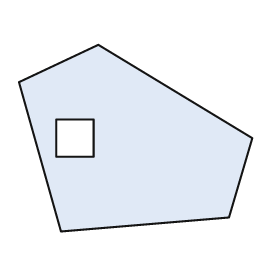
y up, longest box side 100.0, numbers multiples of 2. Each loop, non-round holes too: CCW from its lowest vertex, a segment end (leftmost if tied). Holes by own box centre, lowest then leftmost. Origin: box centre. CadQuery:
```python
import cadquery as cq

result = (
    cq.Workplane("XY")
    .moveTo(-32.0, -40.0)
    .lineTo(40.0, -34.0)
    .lineTo(50.0, 0.0)
    .lineTo(-16.0, 40.0)
    .lineTo(-50.0, 24.0)
    .close()
    .moveTo(-34.0, -8.0)
    .lineTo(-18.0, -8.0)
    .lineTo(-18.0, 8.0)
    .lineTo(-34.0, 8.0)
    .close()
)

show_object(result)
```